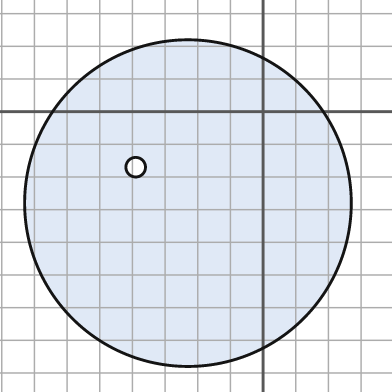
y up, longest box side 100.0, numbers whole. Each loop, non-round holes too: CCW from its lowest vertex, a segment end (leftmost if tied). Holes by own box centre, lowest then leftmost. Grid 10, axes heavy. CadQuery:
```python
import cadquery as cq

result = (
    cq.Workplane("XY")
    .moveTo(-23.0, -28.0)
    .circle(50.0)
    .moveTo(-39.0, -17.0)
    .circle(3.0)
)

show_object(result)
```